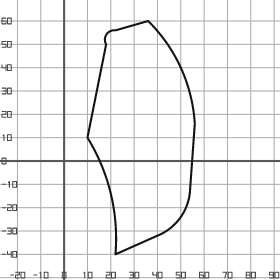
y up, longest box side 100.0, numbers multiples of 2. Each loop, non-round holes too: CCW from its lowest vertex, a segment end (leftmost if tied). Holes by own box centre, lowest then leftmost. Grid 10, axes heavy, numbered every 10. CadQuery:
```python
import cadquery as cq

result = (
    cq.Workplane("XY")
    .moveTo(22.0, -40.0)
    .lineTo(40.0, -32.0)
    .threePointArc((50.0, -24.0), (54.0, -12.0))
    .lineTo(56.0, 16.0)
    .threePointArc((50.0, 40.0), (36.0, 60.0))
    .lineTo(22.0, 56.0)
    .threePointArc((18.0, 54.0), (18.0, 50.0))
    .lineTo(10.0, 10.0)
    .threePointArc((20.0, -14.0), (22.0, -40.0))
    .close()
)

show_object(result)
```